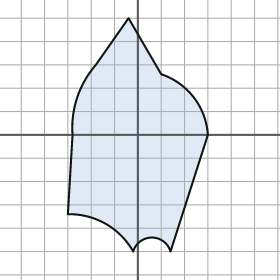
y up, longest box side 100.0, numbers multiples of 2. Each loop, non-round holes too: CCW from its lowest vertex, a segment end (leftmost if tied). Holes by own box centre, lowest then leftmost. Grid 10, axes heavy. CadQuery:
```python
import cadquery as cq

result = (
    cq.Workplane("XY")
    .moveTo(-2.0, -50.0)
    .threePointArc((6.0, -44.0), (14.0, -50.0))
    .lineTo(30.0, 0.0)
    .threePointArc((24.0, 16.0), (10.0, 26.0))
    .lineTo(-4.0, 50.0)
    .lineTo(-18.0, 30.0)
    .threePointArc((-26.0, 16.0), (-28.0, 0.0))
    .lineTo(-30.0, -34.0)
    .threePointArc((-14.0, -38.0), (-2.0, -50.0))
    .close()
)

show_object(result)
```